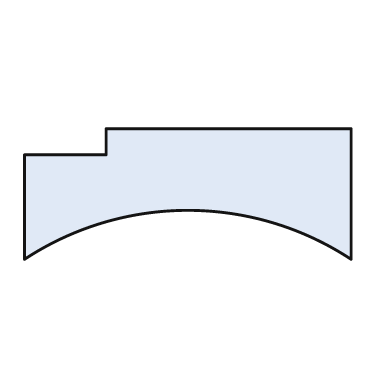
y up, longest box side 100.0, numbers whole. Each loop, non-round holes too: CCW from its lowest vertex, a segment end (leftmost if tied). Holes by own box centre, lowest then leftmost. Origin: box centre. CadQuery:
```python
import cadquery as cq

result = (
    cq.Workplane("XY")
    .moveTo(-50.0, -20.0)
    .threePointArc((0.0, -5.0), (50.0, -20.0))
    .lineTo(50.0, 20.0)
    .lineTo(-25.0, 20.0)
    .lineTo(-25.0, 12.0)
    .lineTo(-50.0, 12.0)
    .close()
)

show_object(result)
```